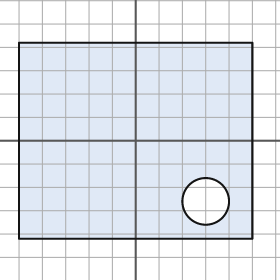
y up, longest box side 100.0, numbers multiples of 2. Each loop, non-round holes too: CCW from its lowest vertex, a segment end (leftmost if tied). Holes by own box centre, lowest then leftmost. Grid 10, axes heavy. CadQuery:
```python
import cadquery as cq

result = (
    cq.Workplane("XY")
    .moveTo(-50.0, -42.0)
    .lineTo(50.0, -42.0)
    .lineTo(50.0, 42.0)
    .lineTo(-50.0, 42.0)
    .close()
    .moveTo(30.0, -26.0)
    .circle(10.0)
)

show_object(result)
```